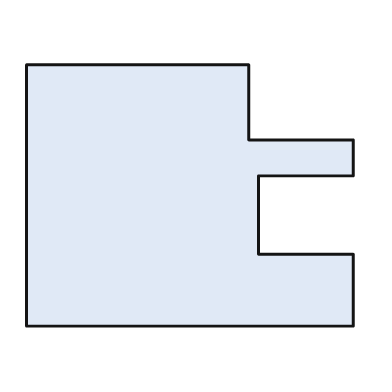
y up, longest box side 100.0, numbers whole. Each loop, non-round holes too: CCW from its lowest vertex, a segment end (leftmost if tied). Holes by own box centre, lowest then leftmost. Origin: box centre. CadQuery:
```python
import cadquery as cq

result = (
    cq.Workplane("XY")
    .moveTo(-50.0, -40.0)
    .lineTo(50.0, -40.0)
    .lineTo(50.0, -18.0)
    .lineTo(21.0, -18.0)
    .lineTo(21.0, 6.0)
    .lineTo(50.0, 6.0)
    .lineTo(50.0, 17.0)
    .lineTo(18.0, 17.0)
    .lineTo(18.0, 40.0)
    .lineTo(-50.0, 40.0)
    .close()
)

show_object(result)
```